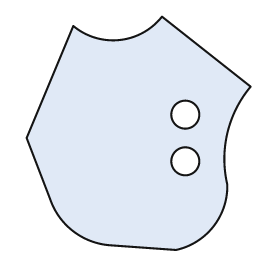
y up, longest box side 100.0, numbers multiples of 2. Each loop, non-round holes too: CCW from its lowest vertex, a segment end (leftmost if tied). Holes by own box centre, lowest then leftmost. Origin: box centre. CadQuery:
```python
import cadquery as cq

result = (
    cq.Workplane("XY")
    .moveTo(16.0, -50.0)
    .threePointArc((32.0, -40.0), (38.0, -22.0))
    .threePointArc((38.0, 0.0), (48.0, 20.0))
    .lineTo(10.0, 50.0)
    .threePointArc((-8.0, 40.0), (-28.0, 46.0))
    .lineTo(-48.0, -2.0)
    .lineTo(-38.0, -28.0)
    .threePointArc((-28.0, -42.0), (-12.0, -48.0))
    .close()
    .moveTo(20.0, -12.0)
    .circle(6.0)
    .moveTo(20.0, 8.0)
    .circle(6.0)
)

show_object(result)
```